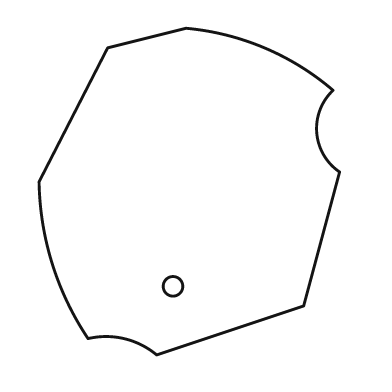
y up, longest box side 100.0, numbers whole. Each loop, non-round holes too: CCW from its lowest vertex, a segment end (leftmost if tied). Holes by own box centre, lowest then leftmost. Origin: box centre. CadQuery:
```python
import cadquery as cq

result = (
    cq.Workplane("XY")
    .moveTo(-10.0, -50.0)
    .lineTo(35.0, -35.0)
    .lineTo(46.0, 6.0)
    .threePointArc((39.0, 18.0), (44.0, 31.0))
    .threePointArc((23.0, 44.0), (-1.0, 50.0))
    .lineTo(-25.0, 44.0)
    .lineTo(-46.0, 3.0)
    .threePointArc((-42.0, -22.0), (-31.0, -45.0))
    .threePointArc((-20.0, -45.0), (-10.0, -50.0))
    .close()
    .moveTo(-5.0, -29.0)
    .circle(3.0)
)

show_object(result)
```